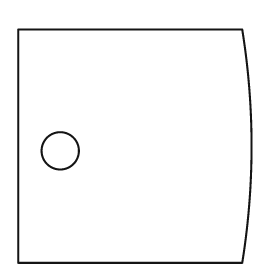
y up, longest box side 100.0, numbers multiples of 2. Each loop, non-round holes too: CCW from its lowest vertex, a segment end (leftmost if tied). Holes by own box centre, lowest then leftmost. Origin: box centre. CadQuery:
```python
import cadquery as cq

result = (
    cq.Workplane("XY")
    .moveTo(-50.0, -50.0)
    .lineTo(46.0, -50.0)
    .threePointArc((50.0, 0.0), (46.0, 50.0))
    .lineTo(-50.0, 50.0)
    .close()
    .moveTo(-32.0, -2.0)
    .circle(8.0)
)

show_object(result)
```